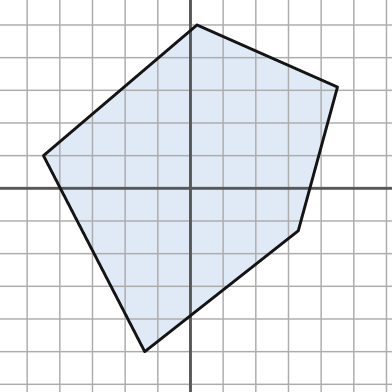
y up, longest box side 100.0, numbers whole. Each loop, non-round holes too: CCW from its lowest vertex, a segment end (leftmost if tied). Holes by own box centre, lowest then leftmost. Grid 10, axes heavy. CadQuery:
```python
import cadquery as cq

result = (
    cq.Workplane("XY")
    .moveTo(-14.0, -50.0)
    .lineTo(33.0, -13.0)
    .lineTo(45.0, 31.0)
    .lineTo(2.0, 50.0)
    .lineTo(-45.0, 10.0)
    .close()
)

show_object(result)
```